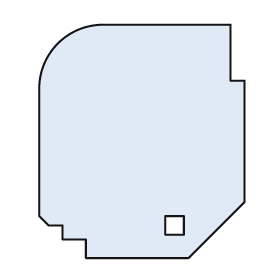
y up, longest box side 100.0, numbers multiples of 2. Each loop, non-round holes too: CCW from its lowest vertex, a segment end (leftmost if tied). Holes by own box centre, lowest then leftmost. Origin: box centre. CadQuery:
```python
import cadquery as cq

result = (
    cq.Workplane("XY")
    .moveTo(-24.0, -50.0)
    .lineTo(20.0, -50.0)
    .lineTo(44.0, -26.0)
    .lineTo(44.0, 26.0)
    .lineTo(38.0, 26.0)
    .lineTo(38.0, 50.0)
    .lineTo(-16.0, 50.0)
    .threePointArc((-36.0, 42.0), (-44.0, 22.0))
    .lineTo(-44.0, -32.0)
    .lineTo(-40.0, -36.0)
    .lineTo(-34.0, -36.0)
    .lineTo(-34.0, -42.0)
    .lineTo(-24.0, -42.0)
    .close()
    .moveTo(10.0, -40.0)
    .lineTo(18.0, -40.0)
    .lineTo(18.0, -32.0)
    .lineTo(10.0, -32.0)
    .close()
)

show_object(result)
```